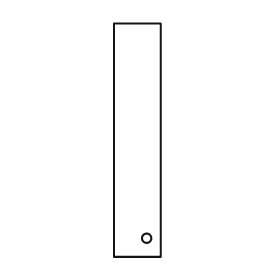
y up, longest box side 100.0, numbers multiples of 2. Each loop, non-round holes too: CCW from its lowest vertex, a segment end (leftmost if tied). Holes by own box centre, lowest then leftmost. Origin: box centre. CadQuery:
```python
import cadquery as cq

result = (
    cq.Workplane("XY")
    .moveTo(-10.0, -50.0)
    .lineTo(10.0, -50.0)
    .lineTo(10.0, 50.0)
    .lineTo(-10.0, 50.0)
    .close()
    .moveTo(4.0, -42.0)
    .circle(2.0)
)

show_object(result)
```